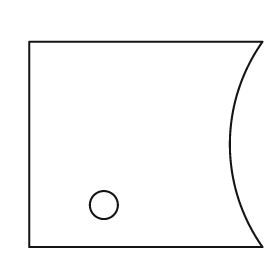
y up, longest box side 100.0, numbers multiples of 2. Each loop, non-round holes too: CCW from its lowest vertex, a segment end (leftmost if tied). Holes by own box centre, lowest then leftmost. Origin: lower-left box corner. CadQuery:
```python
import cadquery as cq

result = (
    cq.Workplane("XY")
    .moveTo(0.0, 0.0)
    .lineTo(100.0, 0.0)
    .threePointArc((86.0, 44.0), (100.0, 88.0))
    .lineTo(0.0, 88.0)
    .close()
    .moveTo(32.0, 18.0)
    .circle(6.0)
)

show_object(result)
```